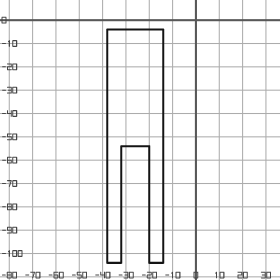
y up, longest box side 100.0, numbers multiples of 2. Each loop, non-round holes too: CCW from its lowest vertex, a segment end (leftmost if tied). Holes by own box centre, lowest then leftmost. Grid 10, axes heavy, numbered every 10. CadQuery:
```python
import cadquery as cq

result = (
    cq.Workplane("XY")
    .moveTo(-38.0, -104.0)
    .lineTo(-32.0, -104.0)
    .lineTo(-32.0, -54.0)
    .lineTo(-20.0, -54.0)
    .lineTo(-20.0, -104.0)
    .lineTo(-14.0, -104.0)
    .lineTo(-14.0, -4.0)
    .lineTo(-38.0, -4.0)
    .close()
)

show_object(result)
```